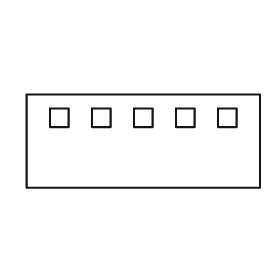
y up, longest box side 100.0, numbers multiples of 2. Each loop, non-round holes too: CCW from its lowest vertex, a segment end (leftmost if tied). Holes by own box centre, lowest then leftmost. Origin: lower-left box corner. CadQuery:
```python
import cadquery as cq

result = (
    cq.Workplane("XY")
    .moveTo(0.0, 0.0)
    .lineTo(100.0, 0.0)
    .lineTo(100.0, 40.0)
    .lineTo(0.0, 40.0)
    .close()
    .moveTo(10.0, 26.0)
    .lineTo(18.0, 26.0)
    .lineTo(18.0, 34.0)
    .lineTo(10.0, 34.0)
    .close()
    .moveTo(28.0, 26.0)
    .lineTo(36.0, 26.0)
    .lineTo(36.0, 34.0)
    .lineTo(28.0, 34.0)
    .close()
    .moveTo(46.0, 26.0)
    .lineTo(54.0, 26.0)
    .lineTo(54.0, 34.0)
    .lineTo(46.0, 34.0)
    .close()
    .moveTo(64.0, 26.0)
    .lineTo(72.0, 26.0)
    .lineTo(72.0, 34.0)
    .lineTo(64.0, 34.0)
    .close()
    .moveTo(82.0, 26.0)
    .lineTo(90.0, 26.0)
    .lineTo(90.0, 34.0)
    .lineTo(82.0, 34.0)
    .close()
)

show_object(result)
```